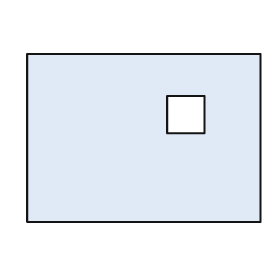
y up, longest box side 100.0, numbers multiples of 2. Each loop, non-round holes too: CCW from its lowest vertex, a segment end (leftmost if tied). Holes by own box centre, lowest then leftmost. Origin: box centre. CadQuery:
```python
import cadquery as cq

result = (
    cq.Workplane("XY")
    .moveTo(-50.0, -36.0)
    .lineTo(50.0, -36.0)
    .lineTo(50.0, 36.0)
    .lineTo(-50.0, 36.0)
    .close()
    .moveTo(10.0, 2.0)
    .lineTo(26.0, 2.0)
    .lineTo(26.0, 18.0)
    .lineTo(10.0, 18.0)
    .close()
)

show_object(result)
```